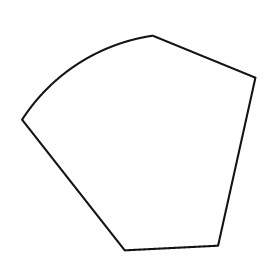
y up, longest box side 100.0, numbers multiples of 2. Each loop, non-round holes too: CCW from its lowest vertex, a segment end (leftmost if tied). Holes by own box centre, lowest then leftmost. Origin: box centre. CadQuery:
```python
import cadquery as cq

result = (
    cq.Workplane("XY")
    .moveTo(-6.0, -46.0)
    .lineTo(34.0, -44.0)
    .lineTo(50.0, 28.0)
    .lineTo(6.0, 46.0)
    .threePointArc((-26.0, 34.0), (-50.0, 10.0))
    .close()
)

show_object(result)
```